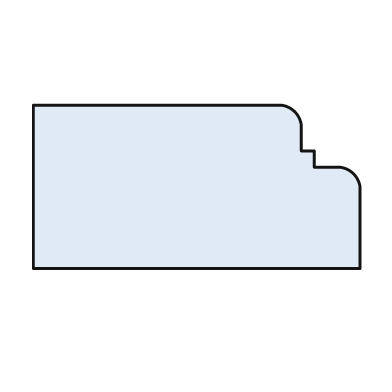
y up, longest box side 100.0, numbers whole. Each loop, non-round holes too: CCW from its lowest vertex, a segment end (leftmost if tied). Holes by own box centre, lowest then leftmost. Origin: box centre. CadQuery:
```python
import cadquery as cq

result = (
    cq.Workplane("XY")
    .moveTo(-50.0, -25.0)
    .lineTo(50.0, -25.0)
    .lineTo(50.0, 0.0)
    .threePointArc((48.0, 4.0), (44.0, 6.0))
    .lineTo(36.0, 6.0)
    .lineTo(36.0, 11.0)
    .lineTo(32.0, 11.0)
    .lineTo(32.0, 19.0)
    .threePointArc((30.0, 23.0), (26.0, 25.0))
    .lineTo(-50.0, 25.0)
    .close()
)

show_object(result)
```